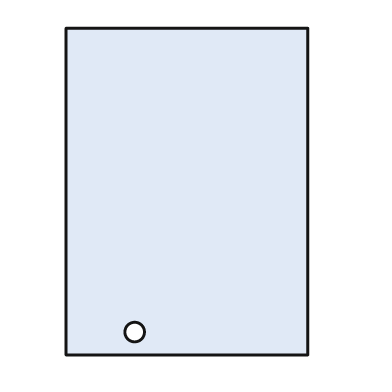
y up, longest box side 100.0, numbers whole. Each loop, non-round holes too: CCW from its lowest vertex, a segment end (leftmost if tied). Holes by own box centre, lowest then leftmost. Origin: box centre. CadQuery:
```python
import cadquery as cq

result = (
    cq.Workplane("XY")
    .moveTo(-37.0, -50.0)
    .lineTo(37.0, -50.0)
    .lineTo(37.0, 50.0)
    .lineTo(-37.0, 50.0)
    .close()
    .moveTo(-16.0, -43.0)
    .circle(3.0)
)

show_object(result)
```